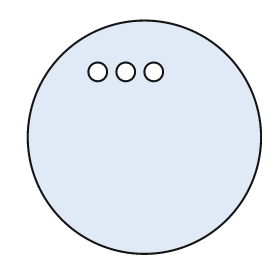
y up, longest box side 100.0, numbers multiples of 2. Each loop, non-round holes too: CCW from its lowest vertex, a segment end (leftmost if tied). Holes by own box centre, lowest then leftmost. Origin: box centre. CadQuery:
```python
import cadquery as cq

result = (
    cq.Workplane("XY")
    .moveTo(0.0, 0.0)
    .circle(50.0)
    .moveTo(-20.0, 28.0)
    .circle(4.0)
    .moveTo(-8.0, 28.0)
    .circle(4.0)
    .moveTo(4.0, 28.0)
    .circle(4.0)
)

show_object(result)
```